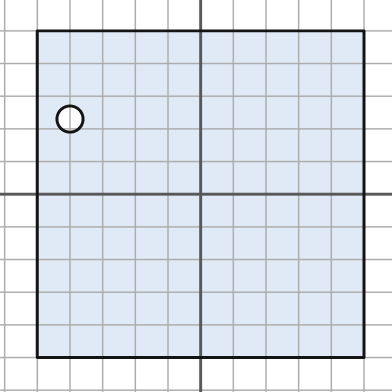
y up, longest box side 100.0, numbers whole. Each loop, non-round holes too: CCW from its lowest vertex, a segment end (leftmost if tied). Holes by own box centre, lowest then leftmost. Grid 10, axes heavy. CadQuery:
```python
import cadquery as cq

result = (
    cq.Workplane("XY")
    .moveTo(-50.0, -50.0)
    .lineTo(50.0, -50.0)
    .lineTo(50.0, 50.0)
    .lineTo(-50.0, 50.0)
    .close()
    .moveTo(-40.0, 23.0)
    .circle(4.0)
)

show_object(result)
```